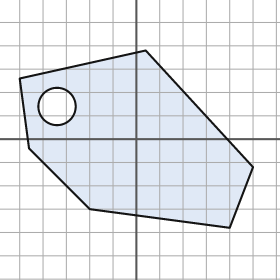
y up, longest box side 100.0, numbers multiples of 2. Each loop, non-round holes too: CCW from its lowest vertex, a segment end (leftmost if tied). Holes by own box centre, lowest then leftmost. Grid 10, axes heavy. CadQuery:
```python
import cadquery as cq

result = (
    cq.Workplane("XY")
    .moveTo(40.0, -38.0)
    .lineTo(50.0, -12.0)
    .lineTo(4.0, 38.0)
    .lineTo(-50.0, 26.0)
    .lineTo(-46.0, -4.0)
    .lineTo(-20.0, -30.0)
    .close()
    .moveTo(-34.0, 14.0)
    .circle(8.0)
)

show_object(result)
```